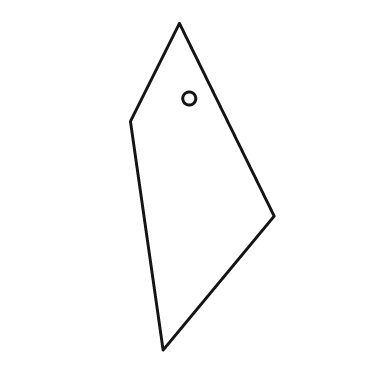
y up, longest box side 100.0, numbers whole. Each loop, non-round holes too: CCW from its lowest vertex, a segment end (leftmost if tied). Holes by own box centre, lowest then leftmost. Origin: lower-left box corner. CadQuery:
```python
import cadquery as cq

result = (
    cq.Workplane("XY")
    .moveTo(10.0, 0.0)
    .lineTo(44.0, 41.0)
    .lineTo(15.0, 100.0)
    .lineTo(0.0, 70.0)
    .close()
    .moveTo(18.0, 77.0)
    .circle(2.0)
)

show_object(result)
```